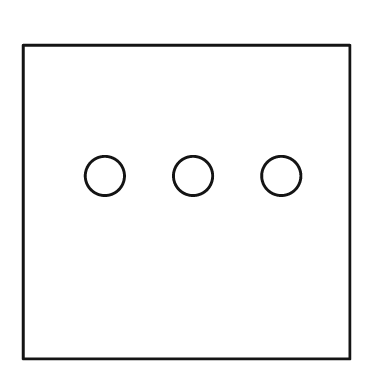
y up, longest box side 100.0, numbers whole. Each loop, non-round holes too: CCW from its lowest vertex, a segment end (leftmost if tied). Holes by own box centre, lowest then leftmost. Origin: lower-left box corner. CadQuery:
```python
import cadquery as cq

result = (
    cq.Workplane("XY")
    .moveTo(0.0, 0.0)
    .lineTo(100.0, 0.0)
    .lineTo(100.0, 96.0)
    .lineTo(0.0, 96.0)
    .close()
    .moveTo(25.0, 56.0)
    .circle(6.0)
    .moveTo(52.0, 56.0)
    .circle(6.0)
    .moveTo(79.0, 56.0)
    .circle(6.0)
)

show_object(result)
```